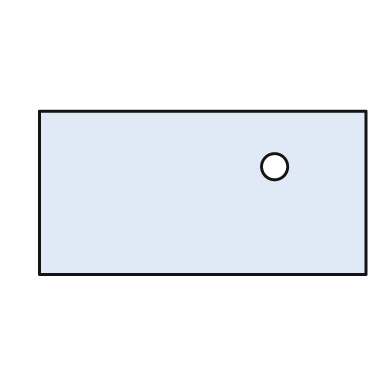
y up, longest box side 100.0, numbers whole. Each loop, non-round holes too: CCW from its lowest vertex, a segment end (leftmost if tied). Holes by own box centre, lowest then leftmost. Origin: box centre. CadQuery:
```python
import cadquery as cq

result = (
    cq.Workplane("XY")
    .moveTo(-50.0, -25.0)
    .lineTo(50.0, -25.0)
    .lineTo(50.0, 25.0)
    .lineTo(-50.0, 25.0)
    .close()
    .moveTo(22.0, 8.0)
    .circle(4.0)
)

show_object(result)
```